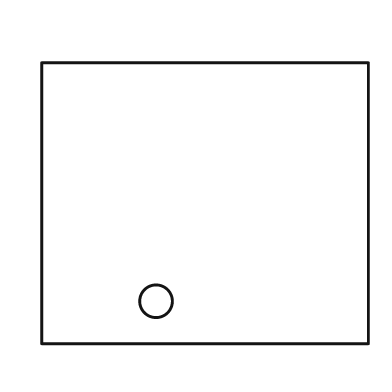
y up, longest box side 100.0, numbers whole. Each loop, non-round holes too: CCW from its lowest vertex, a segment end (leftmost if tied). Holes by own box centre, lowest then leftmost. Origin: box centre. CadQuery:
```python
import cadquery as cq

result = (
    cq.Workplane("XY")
    .moveTo(-50.0, -43.0)
    .lineTo(50.0, -43.0)
    .lineTo(50.0, 43.0)
    .lineTo(-50.0, 43.0)
    .close()
    .moveTo(-15.0, -30.0)
    .circle(5.0)
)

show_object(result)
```